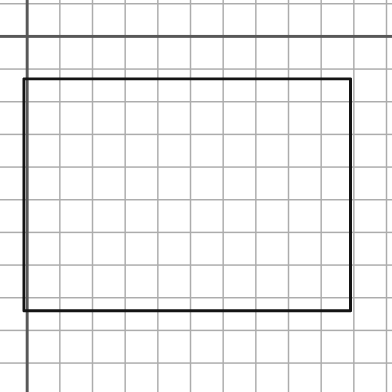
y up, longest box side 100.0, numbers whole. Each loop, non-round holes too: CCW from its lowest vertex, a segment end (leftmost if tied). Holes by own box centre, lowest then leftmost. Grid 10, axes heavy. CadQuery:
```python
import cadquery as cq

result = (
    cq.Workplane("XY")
    .moveTo(-1.0, -84.0)
    .lineTo(99.0, -84.0)
    .lineTo(99.0, -13.0)
    .lineTo(-1.0, -13.0)
    .close()
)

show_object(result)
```